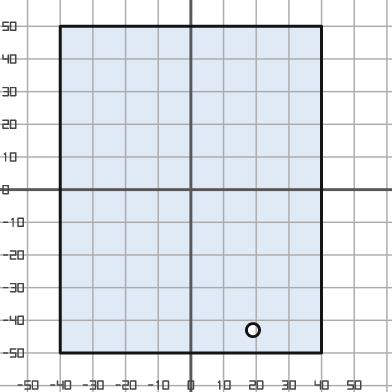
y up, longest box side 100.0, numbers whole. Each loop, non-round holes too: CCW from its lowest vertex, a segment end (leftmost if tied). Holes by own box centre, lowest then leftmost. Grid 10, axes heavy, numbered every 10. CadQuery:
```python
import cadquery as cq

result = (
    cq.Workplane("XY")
    .moveTo(-40.0, -50.0)
    .lineTo(40.0, -50.0)
    .lineTo(40.0, 50.0)
    .lineTo(-40.0, 50.0)
    .close()
    .moveTo(19.0, -43.0)
    .circle(2.0)
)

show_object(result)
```